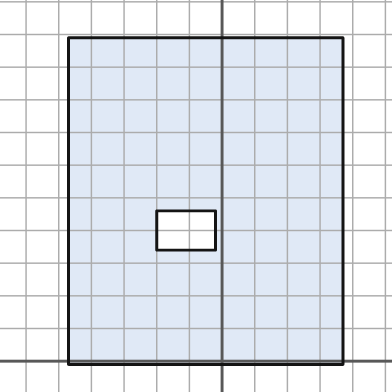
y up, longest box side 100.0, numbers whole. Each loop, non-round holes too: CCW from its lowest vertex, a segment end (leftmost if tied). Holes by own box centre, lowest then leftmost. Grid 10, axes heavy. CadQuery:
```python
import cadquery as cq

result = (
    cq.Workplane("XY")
    .moveTo(-47.0, -1.0)
    .lineTo(37.0, -1.0)
    .lineTo(37.0, 99.0)
    .lineTo(-47.0, 99.0)
    .close()
    .moveTo(-20.0, 34.0)
    .lineTo(-2.0, 34.0)
    .lineTo(-2.0, 46.0)
    .lineTo(-20.0, 46.0)
    .close()
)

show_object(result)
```